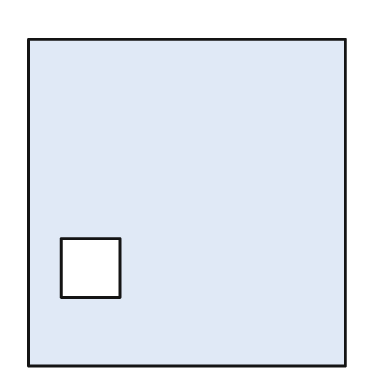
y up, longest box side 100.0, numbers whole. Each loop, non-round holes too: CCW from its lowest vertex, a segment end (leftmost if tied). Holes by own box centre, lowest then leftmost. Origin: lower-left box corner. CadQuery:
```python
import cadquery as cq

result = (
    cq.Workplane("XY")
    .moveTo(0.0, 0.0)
    .lineTo(97.0, 0.0)
    .lineTo(97.0, 100.0)
    .lineTo(0.0, 100.0)
    .close()
    .moveTo(10.0, 21.0)
    .lineTo(28.0, 21.0)
    .lineTo(28.0, 39.0)
    .lineTo(10.0, 39.0)
    .close()
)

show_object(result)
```